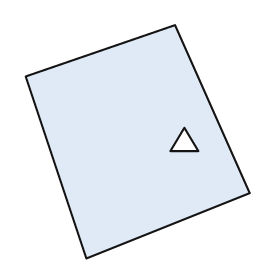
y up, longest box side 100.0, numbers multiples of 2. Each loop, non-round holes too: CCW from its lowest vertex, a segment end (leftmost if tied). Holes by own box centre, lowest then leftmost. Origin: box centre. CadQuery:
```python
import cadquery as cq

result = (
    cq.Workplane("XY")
    .moveTo(-22.0, -50.0)
    .lineTo(48.0, -22.0)
    .lineTo(16.0, 50.0)
    .lineTo(-48.0, 28.0)
    .close()
    .moveTo(14.0, -4.0)
    .lineTo(26.0, -4.0)
    .lineTo(20.0, 6.0)
    .close()
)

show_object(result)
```